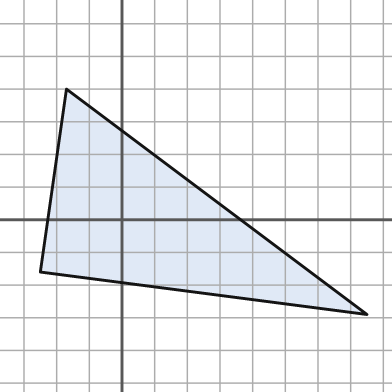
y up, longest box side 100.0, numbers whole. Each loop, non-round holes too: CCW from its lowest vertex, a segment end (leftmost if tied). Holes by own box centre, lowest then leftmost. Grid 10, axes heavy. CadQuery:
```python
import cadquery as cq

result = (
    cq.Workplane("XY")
    .moveTo(75.0, -29.0)
    .lineTo(-17.0, 40.0)
    .lineTo(-25.0, -16.0)
    .close()
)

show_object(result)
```